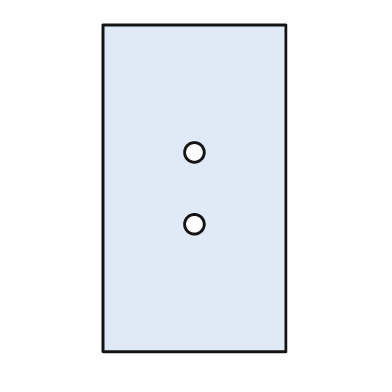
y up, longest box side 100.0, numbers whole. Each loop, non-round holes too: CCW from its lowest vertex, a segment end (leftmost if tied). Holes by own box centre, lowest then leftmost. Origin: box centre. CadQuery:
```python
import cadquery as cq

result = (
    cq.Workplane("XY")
    .moveTo(-28.0, -50.0)
    .lineTo(28.0, -50.0)
    .lineTo(28.0, 50.0)
    .lineTo(-28.0, 50.0)
    .close()
    .moveTo(0.0, -11.0)
    .circle(3.0)
    .moveTo(0.0, 11.0)
    .circle(3.0)
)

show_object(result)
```